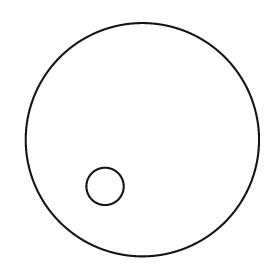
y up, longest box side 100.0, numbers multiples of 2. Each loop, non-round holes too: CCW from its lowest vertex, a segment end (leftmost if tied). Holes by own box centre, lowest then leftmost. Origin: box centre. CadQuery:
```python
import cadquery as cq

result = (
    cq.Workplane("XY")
    .moveTo(0.0, 0.0)
    .circle(50.0)
    .moveTo(-16.0, -20.0)
    .circle(8.0)
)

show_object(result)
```